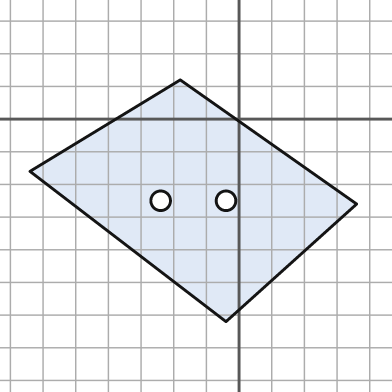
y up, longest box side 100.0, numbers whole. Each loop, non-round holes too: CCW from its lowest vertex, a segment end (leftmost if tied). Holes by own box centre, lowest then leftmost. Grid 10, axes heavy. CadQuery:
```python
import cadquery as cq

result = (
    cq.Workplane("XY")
    .moveTo(-4.0, -62.0)
    .lineTo(36.0, -26.0)
    .lineTo(-18.0, 12.0)
    .lineTo(-64.0, -16.0)
    .close()
    .moveTo(-24.0, -25.0)
    .circle(3.0)
    .moveTo(-4.0, -25.0)
    .circle(3.0)
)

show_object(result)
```